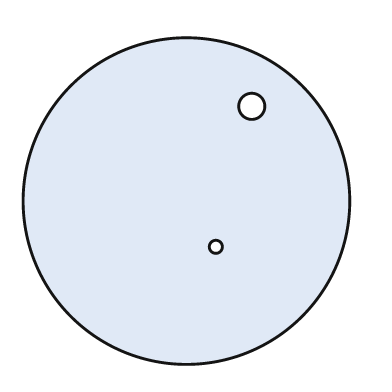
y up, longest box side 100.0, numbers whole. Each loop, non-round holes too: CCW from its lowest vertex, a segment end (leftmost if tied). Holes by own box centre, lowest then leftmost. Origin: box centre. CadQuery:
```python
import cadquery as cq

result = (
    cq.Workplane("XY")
    .moveTo(0.0, 0.0)
    .circle(50.0)
    .moveTo(9.0, -14.0)
    .circle(2.0)
    .moveTo(20.0, 29.0)
    .circle(4.0)
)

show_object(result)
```